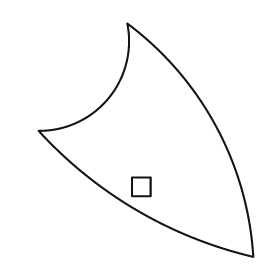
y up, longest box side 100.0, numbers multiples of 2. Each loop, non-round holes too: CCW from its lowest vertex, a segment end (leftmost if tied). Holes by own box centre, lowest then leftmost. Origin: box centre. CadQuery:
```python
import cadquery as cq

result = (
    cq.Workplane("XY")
    .moveTo(46.0, -50.0)
    .threePointArc((30.0, 6.0), (-8.0, 50.0))
    .threePointArc((-16.0, 18.0), (-46.0, 4.0))
    .threePointArc((-4.0, -30.0), (46.0, -50.0))
    .close()
    .moveTo(-6.0, -24.0)
    .lineTo(2.0, -24.0)
    .lineTo(2.0, -16.0)
    .lineTo(-6.0, -16.0)
    .close()
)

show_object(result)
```